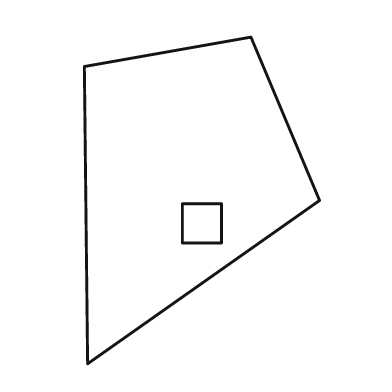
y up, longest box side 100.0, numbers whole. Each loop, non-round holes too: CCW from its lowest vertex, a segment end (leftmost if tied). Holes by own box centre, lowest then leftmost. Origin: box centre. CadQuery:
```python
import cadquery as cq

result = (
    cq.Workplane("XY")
    .moveTo(-35.0, -50.0)
    .lineTo(36.0, 0.0)
    .lineTo(15.0, 50.0)
    .lineTo(-36.0, 41.0)
    .close()
    .moveTo(-6.0, -13.0)
    .lineTo(6.0, -13.0)
    .lineTo(6.0, -1.0)
    .lineTo(-6.0, -1.0)
    .close()
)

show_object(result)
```